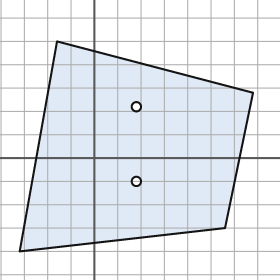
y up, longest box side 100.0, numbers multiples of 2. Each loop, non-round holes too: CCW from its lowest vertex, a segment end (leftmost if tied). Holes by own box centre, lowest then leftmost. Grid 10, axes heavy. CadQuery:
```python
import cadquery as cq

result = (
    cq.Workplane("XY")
    .moveTo(-32.0, -40.0)
    .lineTo(56.0, -30.0)
    .lineTo(68.0, 28.0)
    .lineTo(-16.0, 50.0)
    .close()
    .moveTo(18.0, -10.0)
    .circle(2.0)
    .moveTo(18.0, 22.0)
    .circle(2.0)
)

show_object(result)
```